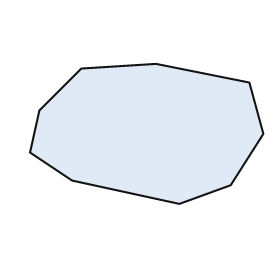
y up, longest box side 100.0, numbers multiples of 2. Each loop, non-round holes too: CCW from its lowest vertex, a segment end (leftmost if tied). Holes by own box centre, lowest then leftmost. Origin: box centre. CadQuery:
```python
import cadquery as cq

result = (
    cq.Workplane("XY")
    .moveTo(14.0, -30.0)
    .lineTo(36.0, -22.0)
    .lineTo(50.0, 0.0)
    .lineTo(44.0, 22.0)
    .lineTo(4.0, 30.0)
    .lineTo(-28.0, 28.0)
    .lineTo(-46.0, 10.0)
    .lineTo(-50.0, -8.0)
    .lineTo(-32.0, -20.0)
    .close()
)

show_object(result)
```